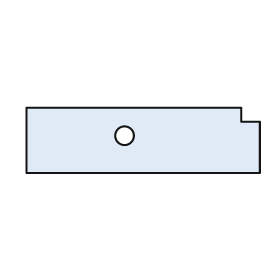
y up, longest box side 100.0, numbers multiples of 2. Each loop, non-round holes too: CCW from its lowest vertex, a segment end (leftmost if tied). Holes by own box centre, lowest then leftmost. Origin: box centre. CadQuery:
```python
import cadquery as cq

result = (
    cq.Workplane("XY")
    .moveTo(-50.0, -14.0)
    .lineTo(50.0, -14.0)
    .lineTo(50.0, 8.0)
    .lineTo(42.0, 8.0)
    .lineTo(42.0, 14.0)
    .lineTo(-50.0, 14.0)
    .close()
    .moveTo(-8.0, 2.0)
    .circle(4.0)
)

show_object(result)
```